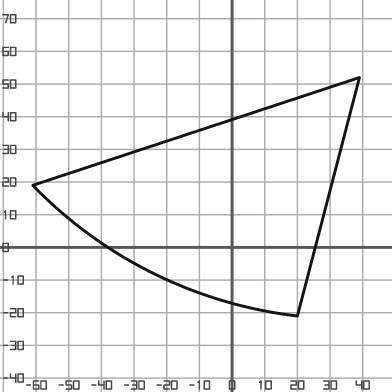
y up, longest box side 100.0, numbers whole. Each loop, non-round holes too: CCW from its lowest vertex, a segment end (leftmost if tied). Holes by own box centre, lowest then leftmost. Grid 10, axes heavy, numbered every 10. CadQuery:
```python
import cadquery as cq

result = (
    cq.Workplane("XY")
    .moveTo(20.0, -21.0)
    .lineTo(39.0, 52.0)
    .lineTo(-61.0, 19.0)
    .threePointArc((-24.0, -8.0), (20.0, -21.0))
    .close()
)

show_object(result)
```